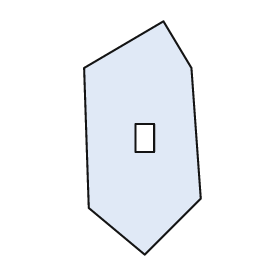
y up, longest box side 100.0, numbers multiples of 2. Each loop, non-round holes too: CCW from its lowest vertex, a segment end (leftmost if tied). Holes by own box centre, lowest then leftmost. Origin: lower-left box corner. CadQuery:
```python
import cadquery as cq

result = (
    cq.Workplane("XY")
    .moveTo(26.0, 0.0)
    .lineTo(50.0, 24.0)
    .lineTo(46.0, 80.0)
    .lineTo(34.0, 100.0)
    .lineTo(0.0, 80.0)
    .lineTo(2.0, 20.0)
    .close()
    .moveTo(22.0, 44.0)
    .lineTo(30.0, 44.0)
    .lineTo(30.0, 56.0)
    .lineTo(22.0, 56.0)
    .close()
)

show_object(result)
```